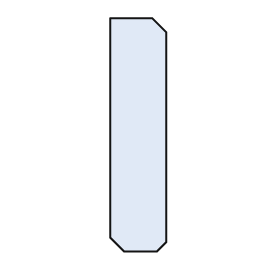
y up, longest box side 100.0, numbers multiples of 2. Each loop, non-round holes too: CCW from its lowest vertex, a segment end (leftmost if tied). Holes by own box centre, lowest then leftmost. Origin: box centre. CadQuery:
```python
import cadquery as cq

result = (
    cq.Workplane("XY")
    .moveTo(-6.0, -50.0)
    .lineTo(8.0, -50.0)
    .lineTo(12.0, -46.0)
    .lineTo(12.0, 44.0)
    .lineTo(6.0, 50.0)
    .lineTo(-12.0, 50.0)
    .lineTo(-12.0, -44.0)
    .close()
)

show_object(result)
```